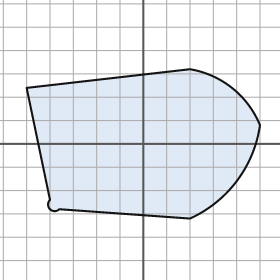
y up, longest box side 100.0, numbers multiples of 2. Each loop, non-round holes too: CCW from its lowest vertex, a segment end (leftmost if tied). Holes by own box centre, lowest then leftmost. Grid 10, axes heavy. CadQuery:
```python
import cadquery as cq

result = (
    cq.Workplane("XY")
    .moveTo(20.0, -32.0)
    .threePointArc((40.0, -16.0), (50.0, 8.0))
    .threePointArc((38.0, 24.0), (20.0, 32.0))
    .lineTo(-50.0, 24.0)
    .lineTo(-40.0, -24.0)
    .threePointArc((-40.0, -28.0), (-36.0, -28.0))
    .close()
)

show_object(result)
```